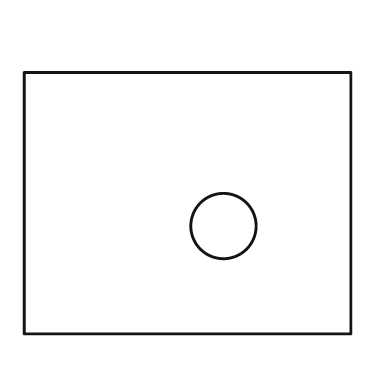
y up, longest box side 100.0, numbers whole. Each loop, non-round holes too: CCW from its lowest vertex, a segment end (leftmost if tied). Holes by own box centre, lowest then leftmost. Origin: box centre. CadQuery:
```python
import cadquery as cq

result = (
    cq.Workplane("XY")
    .moveTo(-50.0, -40.0)
    .lineTo(50.0, -40.0)
    .lineTo(50.0, 40.0)
    .lineTo(-50.0, 40.0)
    .close()
    .moveTo(11.0, -7.0)
    .circle(10.0)
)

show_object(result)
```